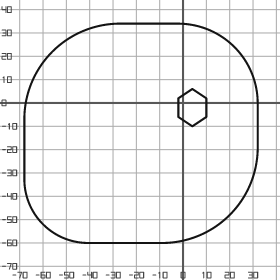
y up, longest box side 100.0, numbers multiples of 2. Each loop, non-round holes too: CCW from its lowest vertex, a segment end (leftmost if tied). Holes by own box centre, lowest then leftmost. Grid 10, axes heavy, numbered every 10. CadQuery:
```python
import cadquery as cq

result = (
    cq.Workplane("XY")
    .moveTo(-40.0, -60.0)
    .lineTo(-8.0, -60.0)
    .threePointArc((20.0, -48.0), (32.0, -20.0))
    .lineTo(32.0, 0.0)
    .threePointArc((22.0, 24.0), (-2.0, 34.0))
    .lineTo(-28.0, 34.0)
    .threePointArc((-56.0, 22.0), (-68.0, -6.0))
    .lineTo(-68.0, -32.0)
    .threePointArc((-60.0, -52.0), (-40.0, -60.0))
    .close()
    .moveTo(4.0, -10.0)
    .lineTo(10.0, -6.0)
    .lineTo(10.0, 2.0)
    .lineTo(4.0, 6.0)
    .lineTo(-2.0, 2.0)
    .lineTo(-2.0, -6.0)
    .close()
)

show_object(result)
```